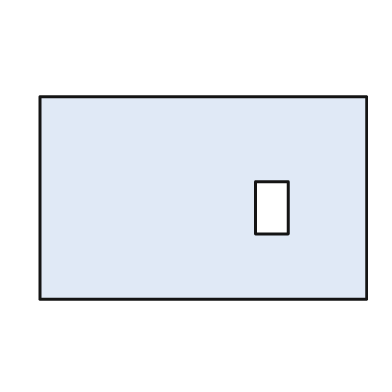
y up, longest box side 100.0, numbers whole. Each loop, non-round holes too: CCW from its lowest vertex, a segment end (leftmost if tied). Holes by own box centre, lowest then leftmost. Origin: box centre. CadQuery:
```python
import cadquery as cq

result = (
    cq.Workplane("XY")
    .moveTo(-50.0, -31.0)
    .lineTo(50.0, -31.0)
    .lineTo(50.0, 31.0)
    .lineTo(-50.0, 31.0)
    .close()
    .moveTo(16.0, -11.0)
    .lineTo(26.0, -11.0)
    .lineTo(26.0, 5.0)
    .lineTo(16.0, 5.0)
    .close()
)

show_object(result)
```